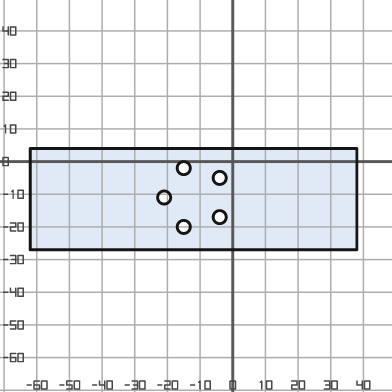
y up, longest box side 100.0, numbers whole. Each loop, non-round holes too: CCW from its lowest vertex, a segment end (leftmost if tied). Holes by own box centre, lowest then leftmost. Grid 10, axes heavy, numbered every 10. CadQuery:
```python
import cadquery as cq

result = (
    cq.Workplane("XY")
    .moveTo(-62.0, -27.0)
    .lineTo(38.0, -27.0)
    .lineTo(38.0, 4.0)
    .lineTo(-62.0, 4.0)
    .close()
    .moveTo(-15.0, -20.0)
    .circle(2.0)
    .moveTo(-4.0, -17.0)
    .circle(2.0)
    .moveTo(-21.0, -11.0)
    .circle(2.0)
    .moveTo(-4.0, -5.0)
    .circle(2.0)
    .moveTo(-15.0, -2.0)
    .circle(2.0)
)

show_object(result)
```